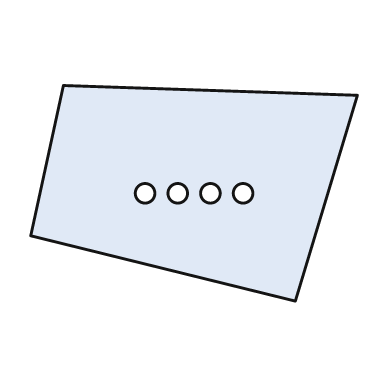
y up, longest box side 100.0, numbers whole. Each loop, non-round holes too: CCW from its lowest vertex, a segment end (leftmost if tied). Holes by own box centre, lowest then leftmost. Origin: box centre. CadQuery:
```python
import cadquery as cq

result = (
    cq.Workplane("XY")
    .moveTo(31.0, -33.0)
    .lineTo(50.0, 30.0)
    .lineTo(-40.0, 33.0)
    .lineTo(-50.0, -13.0)
    .close()
    .moveTo(-15.0, 0.0)
    .circle(3.0)
    .moveTo(-5.0, 0.0)
    .circle(3.0)
    .moveTo(5.0, 0.0)
    .circle(3.0)
    .moveTo(15.0, 0.0)
    .circle(3.0)
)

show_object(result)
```